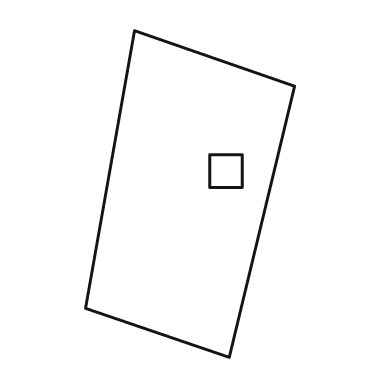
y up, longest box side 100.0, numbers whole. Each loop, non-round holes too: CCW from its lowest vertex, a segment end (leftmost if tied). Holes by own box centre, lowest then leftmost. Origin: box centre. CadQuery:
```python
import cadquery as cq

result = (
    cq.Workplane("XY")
    .moveTo(12.0, -50.0)
    .lineTo(32.0, 33.0)
    .lineTo(-17.0, 50.0)
    .lineTo(-32.0, -35.0)
    .close()
    .moveTo(6.0, 2.0)
    .lineTo(16.0, 2.0)
    .lineTo(16.0, 12.0)
    .lineTo(6.0, 12.0)
    .close()
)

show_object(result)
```